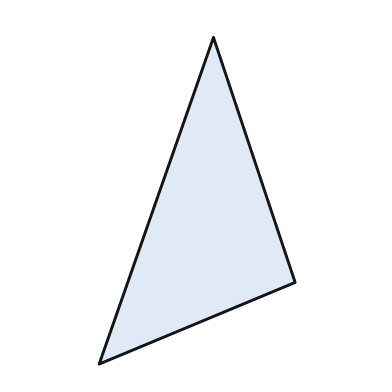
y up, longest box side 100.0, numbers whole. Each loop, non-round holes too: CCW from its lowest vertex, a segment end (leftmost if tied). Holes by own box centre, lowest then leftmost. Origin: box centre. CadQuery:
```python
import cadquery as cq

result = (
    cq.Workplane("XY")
    .moveTo(-30.0, -50.0)
    .lineTo(30.0, -25.0)
    .lineTo(5.0, 50.0)
    .close()
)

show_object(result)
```